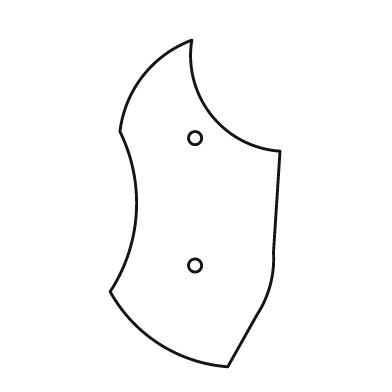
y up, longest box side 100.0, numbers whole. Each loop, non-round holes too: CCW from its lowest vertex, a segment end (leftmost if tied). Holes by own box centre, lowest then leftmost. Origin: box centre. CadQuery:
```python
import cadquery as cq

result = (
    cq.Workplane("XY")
    .moveTo(10.0, -50.0)
    .lineTo(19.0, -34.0)
    .threePointArc((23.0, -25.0), (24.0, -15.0))
    .lineTo(26.0, 16.0)
    .threePointArc((5.0, 27.0), (-1.0, 50.0))
    .threePointArc((-16.0, 39.0), (-23.0, 22.0))
    .threePointArc((-18.0, -3.0), (-26.0, -27.0))
    .threePointArc((-11.0, -43.0), (10.0, -50.0))
    .close()
    .moveTo(0.0, -19.0)
    .circle(2.0)
    .moveTo(0.0, 20.0)
    .circle(2.0)
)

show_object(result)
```